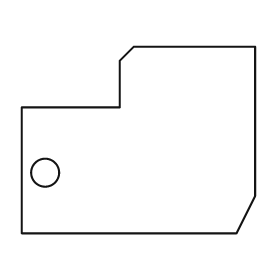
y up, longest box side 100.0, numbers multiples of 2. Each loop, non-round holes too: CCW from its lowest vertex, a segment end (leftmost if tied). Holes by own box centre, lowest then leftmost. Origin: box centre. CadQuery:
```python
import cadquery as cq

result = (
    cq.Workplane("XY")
    .moveTo(-50.0, -40.0)
    .lineTo(42.0, -40.0)
    .lineTo(50.0, -24.0)
    .lineTo(50.0, 40.0)
    .lineTo(-2.0, 40.0)
    .lineTo(-8.0, 34.0)
    .lineTo(-8.0, 14.0)
    .lineTo(-50.0, 14.0)
    .close()
    .moveTo(-40.0, -14.0)
    .circle(6.0)
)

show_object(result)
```